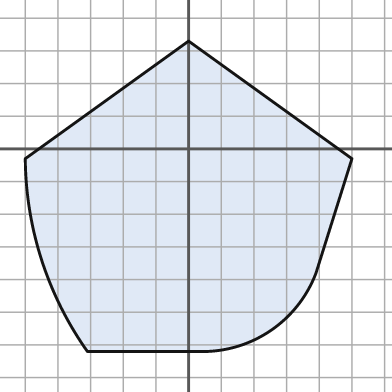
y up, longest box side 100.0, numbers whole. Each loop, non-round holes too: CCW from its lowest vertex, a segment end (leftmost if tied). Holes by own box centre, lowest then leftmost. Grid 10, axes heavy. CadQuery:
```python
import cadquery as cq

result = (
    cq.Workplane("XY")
    .moveTo(-31.0, -62.0)
    .lineTo(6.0, -62.0)
    .threePointArc((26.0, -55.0), (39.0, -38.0))
    .lineTo(50.0, -3.0)
    .lineTo(0.0, 33.0)
    .lineTo(-50.0, -3.0)
    .threePointArc((-45.0, -34.0), (-31.0, -62.0))
    .close()
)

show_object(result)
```